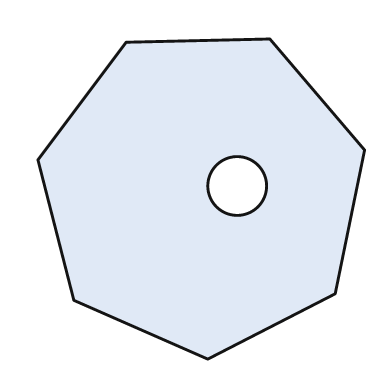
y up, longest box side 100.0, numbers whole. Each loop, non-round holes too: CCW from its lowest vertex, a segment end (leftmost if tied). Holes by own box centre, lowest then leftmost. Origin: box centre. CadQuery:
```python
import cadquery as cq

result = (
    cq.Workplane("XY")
    .moveTo(2.0, -49.0)
    .lineTo(41.0, -29.0)
    .lineTo(50.0, 15.0)
    .lineTo(21.0, 49.0)
    .lineTo(-23.0, 48.0)
    .lineTo(-50.0, 12.0)
    .lineTo(-39.0, -31.0)
    .close()
    .moveTo(11.0, 4.0)
    .circle(9.0)
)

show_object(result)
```